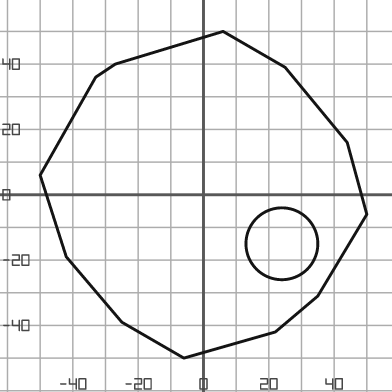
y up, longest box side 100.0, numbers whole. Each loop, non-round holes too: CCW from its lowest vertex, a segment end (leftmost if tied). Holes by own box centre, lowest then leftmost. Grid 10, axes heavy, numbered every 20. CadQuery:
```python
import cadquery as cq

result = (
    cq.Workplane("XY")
    .moveTo(-6.0, -50.0)
    .lineTo(22.0, -42.0)
    .lineTo(35.0, -31.0)
    .lineTo(50.0, -6.0)
    .lineTo(44.0, 16.0)
    .lineTo(25.0, 39.0)
    .lineTo(6.0, 50.0)
    .lineTo(-27.0, 40.0)
    .lineTo(-33.0, 36.0)
    .lineTo(-50.0, 6.0)
    .lineTo(-42.0, -19.0)
    .lineTo(-25.0, -39.0)
    .close()
    .moveTo(24.0, -15.0)
    .circle(11.0)
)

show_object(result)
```